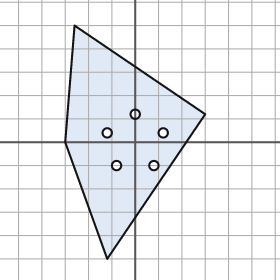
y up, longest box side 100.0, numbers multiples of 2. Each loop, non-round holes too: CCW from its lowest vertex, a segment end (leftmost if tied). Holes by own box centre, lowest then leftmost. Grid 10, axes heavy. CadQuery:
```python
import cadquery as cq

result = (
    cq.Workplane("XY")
    .moveTo(-12.0, -50.0)
    .lineTo(30.0, 12.0)
    .lineTo(-26.0, 50.0)
    .lineTo(-30.0, 0.0)
    .close()
    .moveTo(-8.0, -10.0)
    .circle(2.0)
    .moveTo(8.0, -10.0)
    .circle(2.0)
    .moveTo(-12.0, 4.0)
    .circle(2.0)
    .moveTo(12.0, 4.0)
    .circle(2.0)
    .moveTo(0.0, 12.0)
    .circle(2.0)
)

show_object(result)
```